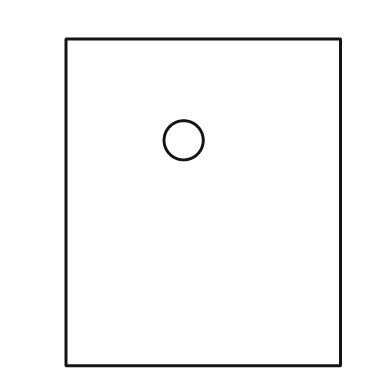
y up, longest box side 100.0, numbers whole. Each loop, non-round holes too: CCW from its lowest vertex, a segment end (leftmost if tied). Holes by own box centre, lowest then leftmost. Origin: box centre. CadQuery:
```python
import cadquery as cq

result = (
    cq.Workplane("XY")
    .moveTo(-42.0, -50.0)
    .lineTo(42.0, -50.0)
    .lineTo(42.0, 50.0)
    .lineTo(-42.0, 50.0)
    .close()
    .moveTo(-6.0, 19.0)
    .circle(6.0)
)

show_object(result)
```